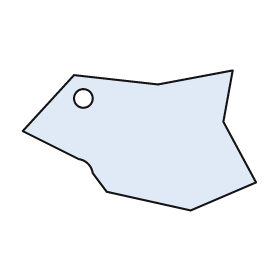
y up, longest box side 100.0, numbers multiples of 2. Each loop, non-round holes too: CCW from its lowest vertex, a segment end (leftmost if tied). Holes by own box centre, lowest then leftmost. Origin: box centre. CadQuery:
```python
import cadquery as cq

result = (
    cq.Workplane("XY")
    .moveTo(22.0, -30.0)
    .lineTo(50.0, -18.0)
    .lineTo(36.0, 8.0)
    .lineTo(40.0, 30.0)
    .lineTo(8.0, 24.0)
    .lineTo(-28.0, 28.0)
    .lineTo(-50.0, 4.0)
    .lineTo(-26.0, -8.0)
    .threePointArc((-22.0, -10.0), (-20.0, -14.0))
    .lineTo(-14.0, -22.0)
    .close()
    .moveTo(-24.0, 18.0)
    .circle(4.0)
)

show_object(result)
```